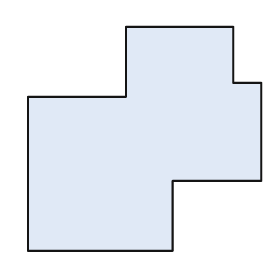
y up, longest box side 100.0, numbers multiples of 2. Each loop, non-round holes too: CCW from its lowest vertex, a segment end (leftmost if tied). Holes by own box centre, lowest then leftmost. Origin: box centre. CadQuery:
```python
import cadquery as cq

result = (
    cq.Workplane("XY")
    .moveTo(-50.0, -48.0)
    .lineTo(12.0, -48.0)
    .lineTo(12.0, -18.0)
    .lineTo(50.0, -18.0)
    .lineTo(50.0, 24.0)
    .lineTo(38.0, 24.0)
    .lineTo(38.0, 48.0)
    .lineTo(-8.0, 48.0)
    .lineTo(-8.0, 18.0)
    .lineTo(-50.0, 18.0)
    .close()
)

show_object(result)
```